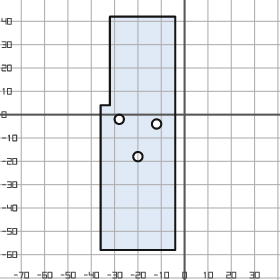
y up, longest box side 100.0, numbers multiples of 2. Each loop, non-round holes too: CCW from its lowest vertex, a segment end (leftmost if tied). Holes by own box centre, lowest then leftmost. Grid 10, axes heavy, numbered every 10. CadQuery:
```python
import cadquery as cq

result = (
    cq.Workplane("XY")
    .moveTo(-36.0, -58.0)
    .lineTo(-4.0, -58.0)
    .lineTo(-4.0, 42.0)
    .lineTo(-32.0, 42.0)
    .lineTo(-32.0, 4.0)
    .lineTo(-36.0, 4.0)
    .close()
    .moveTo(-20.0, -18.0)
    .circle(2.0)
    .moveTo(-12.0, -4.0)
    .circle(2.0)
    .moveTo(-28.0, -2.0)
    .circle(2.0)
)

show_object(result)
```